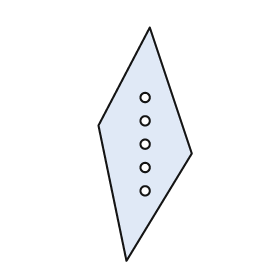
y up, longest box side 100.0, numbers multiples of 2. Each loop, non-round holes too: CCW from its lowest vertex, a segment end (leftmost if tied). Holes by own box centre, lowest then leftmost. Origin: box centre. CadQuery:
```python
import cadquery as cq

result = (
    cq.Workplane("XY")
    .moveTo(-8.0, -50.0)
    .lineTo(20.0, -4.0)
    .lineTo(2.0, 50.0)
    .lineTo(-20.0, 8.0)
    .close()
    .moveTo(0.0, -20.0)
    .circle(2.0)
    .moveTo(0.0, -10.0)
    .circle(2.0)
    .moveTo(0.0, 0.0)
    .circle(2.0)
    .moveTo(0.0, 10.0)
    .circle(2.0)
    .moveTo(0.0, 20.0)
    .circle(2.0)
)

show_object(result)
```